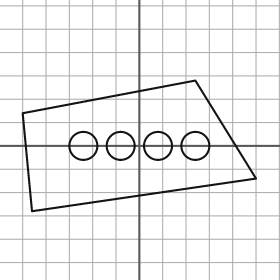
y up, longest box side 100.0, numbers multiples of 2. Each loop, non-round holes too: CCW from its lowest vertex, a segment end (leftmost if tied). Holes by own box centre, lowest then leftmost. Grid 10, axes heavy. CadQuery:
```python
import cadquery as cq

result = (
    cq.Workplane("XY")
    .moveTo(-46.0, -28.0)
    .lineTo(50.0, -14.0)
    .lineTo(24.0, 28.0)
    .lineTo(-50.0, 14.0)
    .close()
    .moveTo(-24.0, 0.0)
    .circle(6.0)
    .moveTo(-8.0, 0.0)
    .circle(6.0)
    .moveTo(8.0, 0.0)
    .circle(6.0)
    .moveTo(24.0, 0.0)
    .circle(6.0)
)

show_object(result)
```